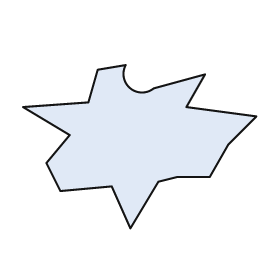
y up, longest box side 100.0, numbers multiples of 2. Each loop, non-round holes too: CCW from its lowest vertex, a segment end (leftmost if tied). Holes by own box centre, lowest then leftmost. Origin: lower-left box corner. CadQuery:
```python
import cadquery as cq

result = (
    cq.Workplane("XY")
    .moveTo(46.0, 0.0)
    .lineTo(58.0, 20.0)
    .lineTo(66.0, 22.0)
    .lineTo(80.0, 22.0)
    .lineTo(88.0, 36.0)
    .lineTo(100.0, 48.0)
    .lineTo(70.0, 52.0)
    .lineTo(78.0, 66.0)
    .lineTo(56.0, 60.0)
    .threePointArc((46.0, 60.0), (44.0, 70.0))
    .lineTo(32.0, 68.0)
    .lineTo(28.0, 54.0)
    .lineTo(0.0, 52.0)
    .lineTo(20.0, 40.0)
    .lineTo(10.0, 28.0)
    .lineTo(16.0, 16.0)
    .lineTo(38.0, 18.0)
    .close()
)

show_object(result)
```